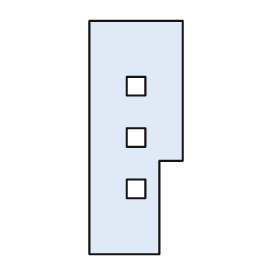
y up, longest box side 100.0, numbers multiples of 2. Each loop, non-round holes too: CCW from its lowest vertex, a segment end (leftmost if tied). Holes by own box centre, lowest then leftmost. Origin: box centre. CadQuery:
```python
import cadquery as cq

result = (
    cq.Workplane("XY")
    .moveTo(-20.0, -50.0)
    .lineTo(10.0, -50.0)
    .lineTo(10.0, -10.0)
    .lineTo(20.0, -10.0)
    .lineTo(20.0, 50.0)
    .lineTo(-20.0, 50.0)
    .close()
    .moveTo(-4.0, -26.0)
    .lineTo(4.0, -26.0)
    .lineTo(4.0, -18.0)
    .lineTo(-4.0, -18.0)
    .close()
    .moveTo(-4.0, -4.0)
    .lineTo(4.0, -4.0)
    .lineTo(4.0, 4.0)
    .lineTo(-4.0, 4.0)
    .close()
    .moveTo(-4.0, 18.0)
    .lineTo(4.0, 18.0)
    .lineTo(4.0, 26.0)
    .lineTo(-4.0, 26.0)
    .close()
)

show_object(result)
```